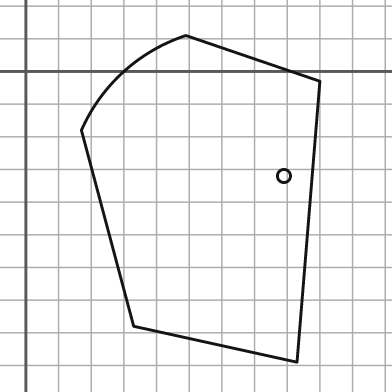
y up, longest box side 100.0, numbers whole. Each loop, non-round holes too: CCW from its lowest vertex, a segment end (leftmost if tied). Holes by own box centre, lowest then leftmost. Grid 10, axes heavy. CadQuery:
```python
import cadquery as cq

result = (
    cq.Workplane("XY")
    .moveTo(83.0, -89.0)
    .lineTo(90.0, -3.0)
    .lineTo(49.0, 11.0)
    .threePointArc((30.0, 0.0), (17.0, -18.0))
    .lineTo(33.0, -78.0)
    .close()
    .moveTo(79.0, -32.0)
    .circle(2.0)
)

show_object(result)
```